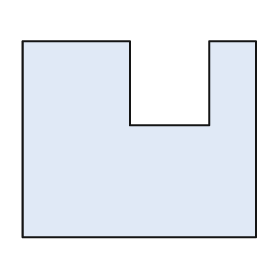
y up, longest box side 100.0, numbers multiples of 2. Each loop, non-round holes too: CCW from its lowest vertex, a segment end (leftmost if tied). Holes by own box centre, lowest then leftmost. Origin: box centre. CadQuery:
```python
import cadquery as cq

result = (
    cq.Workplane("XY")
    .moveTo(-50.0, -42.0)
    .lineTo(50.0, -42.0)
    .lineTo(50.0, 42.0)
    .lineTo(30.0, 42.0)
    .lineTo(30.0, 6.0)
    .lineTo(-4.0, 6.0)
    .lineTo(-4.0, 42.0)
    .lineTo(-50.0, 42.0)
    .close()
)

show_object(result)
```